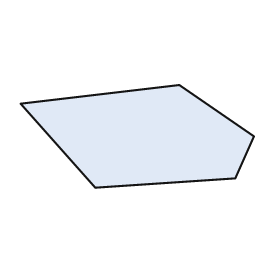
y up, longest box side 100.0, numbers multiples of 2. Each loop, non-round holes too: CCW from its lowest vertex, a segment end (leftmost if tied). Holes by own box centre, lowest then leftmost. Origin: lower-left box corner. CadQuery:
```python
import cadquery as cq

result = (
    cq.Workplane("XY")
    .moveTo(32.0, 0.0)
    .lineTo(92.0, 4.0)
    .lineTo(100.0, 22.0)
    .lineTo(68.0, 44.0)
    .lineTo(0.0, 36.0)
    .close()
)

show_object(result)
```